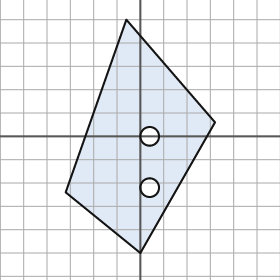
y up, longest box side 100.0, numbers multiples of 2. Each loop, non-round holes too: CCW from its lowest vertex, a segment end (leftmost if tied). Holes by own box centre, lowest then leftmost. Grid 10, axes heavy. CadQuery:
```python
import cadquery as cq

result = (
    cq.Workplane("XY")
    .moveTo(0.0, -50.0)
    .lineTo(32.0, 6.0)
    .lineTo(-6.0, 50.0)
    .lineTo(-32.0, -24.0)
    .close()
    .moveTo(4.0, -22.0)
    .circle(4.0)
    .moveTo(4.0, 0.0)
    .circle(4.0)
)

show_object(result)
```